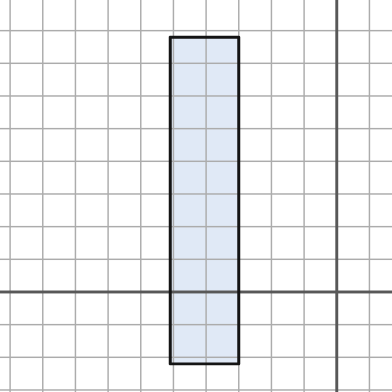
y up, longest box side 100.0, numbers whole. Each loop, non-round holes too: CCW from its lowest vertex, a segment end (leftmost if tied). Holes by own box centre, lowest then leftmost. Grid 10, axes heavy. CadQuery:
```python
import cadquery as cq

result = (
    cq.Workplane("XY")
    .moveTo(-51.0, -22.0)
    .lineTo(-30.0, -22.0)
    .lineTo(-30.0, 78.0)
    .lineTo(-51.0, 78.0)
    .close()
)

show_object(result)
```